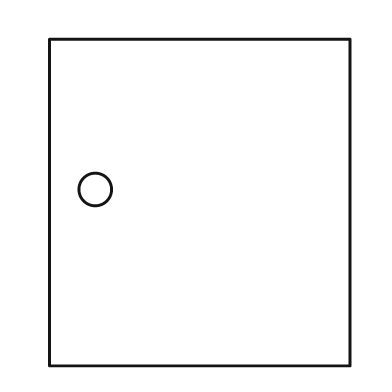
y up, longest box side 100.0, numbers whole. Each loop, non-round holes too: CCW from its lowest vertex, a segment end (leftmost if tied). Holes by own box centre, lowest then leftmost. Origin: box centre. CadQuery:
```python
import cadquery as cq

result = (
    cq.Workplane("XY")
    .moveTo(-46.0, -50.0)
    .lineTo(46.0, -50.0)
    .lineTo(46.0, 50.0)
    .lineTo(-46.0, 50.0)
    .close()
    .moveTo(-32.0, 4.0)
    .circle(5.0)
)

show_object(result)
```